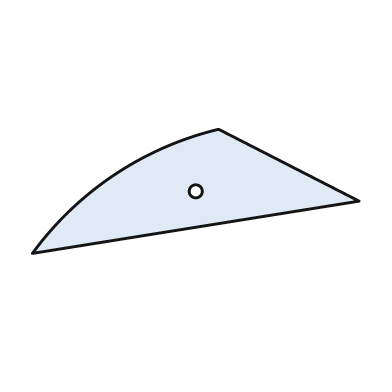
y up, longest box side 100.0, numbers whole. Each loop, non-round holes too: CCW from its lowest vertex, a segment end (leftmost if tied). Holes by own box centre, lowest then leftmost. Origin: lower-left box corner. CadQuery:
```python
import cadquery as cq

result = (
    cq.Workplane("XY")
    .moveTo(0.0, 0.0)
    .lineTo(100.0, 16.0)
    .lineTo(57.0, 38.0)
    .threePointArc((25.0, 24.0), (0.0, 0.0))
    .close()
    .moveTo(50.0, 19.0)
    .circle(2.0)
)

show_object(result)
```